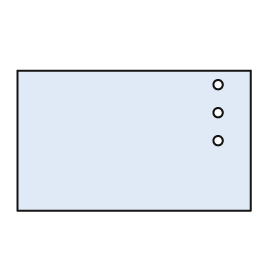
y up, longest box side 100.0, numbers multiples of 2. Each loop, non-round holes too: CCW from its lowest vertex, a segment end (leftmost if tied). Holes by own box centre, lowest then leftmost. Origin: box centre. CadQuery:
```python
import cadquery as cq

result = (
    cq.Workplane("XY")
    .moveTo(-50.0, -30.0)
    .lineTo(50.0, -30.0)
    .lineTo(50.0, 30.0)
    .lineTo(-50.0, 30.0)
    .close()
    .moveTo(36.0, 0.0)
    .circle(2.0)
    .moveTo(36.0, 12.0)
    .circle(2.0)
    .moveTo(36.0, 24.0)
    .circle(2.0)
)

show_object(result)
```